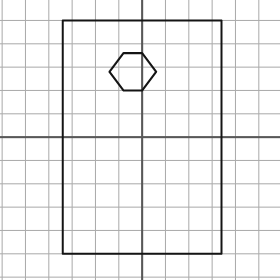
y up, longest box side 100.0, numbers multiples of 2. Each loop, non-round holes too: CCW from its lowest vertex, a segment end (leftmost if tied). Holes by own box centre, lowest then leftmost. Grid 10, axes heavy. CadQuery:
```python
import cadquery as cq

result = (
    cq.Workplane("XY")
    .moveTo(-34.0, -50.0)
    .lineTo(34.0, -50.0)
    .lineTo(34.0, 50.0)
    .lineTo(-34.0, 50.0)
    .close()
    .moveTo(-8.0, 20.0)
    .lineTo(0.0, 20.0)
    .lineTo(6.0, 28.0)
    .lineTo(0.0, 36.0)
    .lineTo(-8.0, 36.0)
    .lineTo(-14.0, 28.0)
    .close()
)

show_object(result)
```